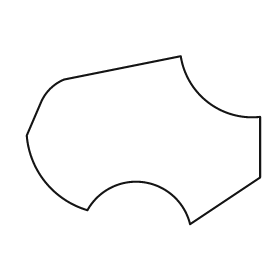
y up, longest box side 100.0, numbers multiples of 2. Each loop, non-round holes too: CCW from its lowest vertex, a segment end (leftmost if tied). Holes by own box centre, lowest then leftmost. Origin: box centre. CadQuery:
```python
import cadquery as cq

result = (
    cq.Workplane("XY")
    .moveTo(20.0, -36.0)
    .lineTo(50.0, -16.0)
    .lineTo(50.0, 10.0)
    .threePointArc((28.0, 16.0), (16.0, 36.0))
    .lineTo(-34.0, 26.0)
    .threePointArc((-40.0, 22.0), (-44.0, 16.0))
    .lineTo(-50.0, 2.0)
    .threePointArc((-42.0, -18.0), (-24.0, -30.0))
    .threePointArc((0.0, -18.0), (20.0, -36.0))
    .close()
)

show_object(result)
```